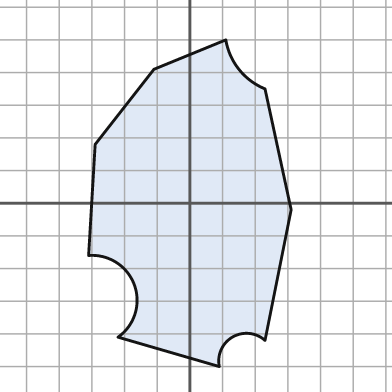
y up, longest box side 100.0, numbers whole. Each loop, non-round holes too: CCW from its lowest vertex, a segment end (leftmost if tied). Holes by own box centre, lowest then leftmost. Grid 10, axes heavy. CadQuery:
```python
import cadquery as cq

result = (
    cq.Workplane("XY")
    .moveTo(9.0, -50.0)
    .threePointArc((13.0, -41.0), (23.0, -42.0))
    .lineTo(31.0, -2.0)
    .lineTo(23.0, 35.0)
    .threePointArc((15.0, 41.0), (11.0, 50.0))
    .lineTo(-11.0, 41.0)
    .lineTo(-29.0, 18.0)
    .lineTo(-31.0, -16.0)
    .threePointArc((-17.0, -25.0), (-22.0, -41.0))
    .close()
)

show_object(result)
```